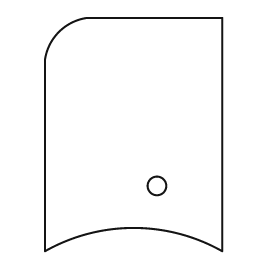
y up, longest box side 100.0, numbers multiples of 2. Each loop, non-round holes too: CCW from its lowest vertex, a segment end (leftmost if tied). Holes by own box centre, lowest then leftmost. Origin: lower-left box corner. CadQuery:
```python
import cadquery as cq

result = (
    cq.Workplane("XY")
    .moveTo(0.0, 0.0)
    .threePointArc((38.0, 10.0), (76.0, 0.0))
    .lineTo(76.0, 100.0)
    .lineTo(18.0, 100.0)
    .threePointArc((6.0, 94.0), (0.0, 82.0))
    .close()
    .moveTo(48.0, 28.0)
    .circle(4.0)
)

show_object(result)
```